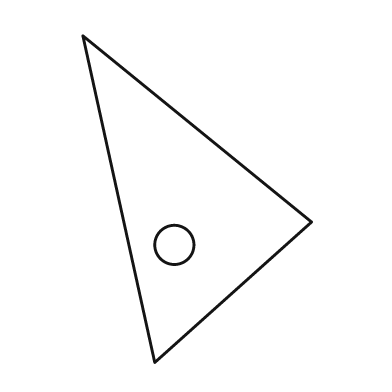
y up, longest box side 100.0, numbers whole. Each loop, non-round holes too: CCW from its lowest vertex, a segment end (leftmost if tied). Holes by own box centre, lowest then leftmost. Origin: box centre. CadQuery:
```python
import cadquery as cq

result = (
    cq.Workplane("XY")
    .moveTo(-13.0, -50.0)
    .lineTo(35.0, -7.0)
    .lineTo(-35.0, 50.0)
    .close()
    .moveTo(-7.0, -14.0)
    .circle(6.0)
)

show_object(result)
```